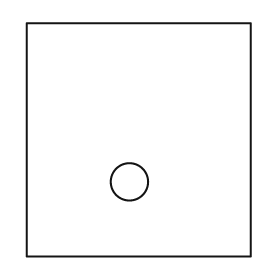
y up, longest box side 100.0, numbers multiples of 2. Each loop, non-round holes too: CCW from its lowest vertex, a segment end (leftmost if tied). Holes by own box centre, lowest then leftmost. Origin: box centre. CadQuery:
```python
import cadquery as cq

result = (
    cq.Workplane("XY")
    .moveTo(-48.0, -50.0)
    .lineTo(48.0, -50.0)
    .lineTo(48.0, 50.0)
    .lineTo(-48.0, 50.0)
    .close()
    .moveTo(-4.0, -18.0)
    .circle(8.0)
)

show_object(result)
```